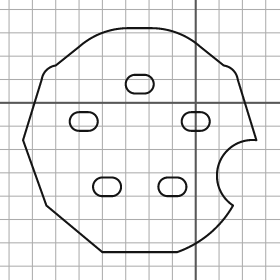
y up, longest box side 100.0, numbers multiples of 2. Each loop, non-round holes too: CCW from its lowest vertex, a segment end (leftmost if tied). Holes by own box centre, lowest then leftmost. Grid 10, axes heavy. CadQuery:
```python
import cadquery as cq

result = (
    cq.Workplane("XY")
    .moveTo(-40.0, -64.0)
    .lineTo(-8.0, -64.0)
    .threePointArc((6.0, -56.0), (16.0, -44.0))
    .threePointArc((10.0, -26.0), (26.0, -16.0))
    .lineTo(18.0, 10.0)
    .threePointArc((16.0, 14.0), (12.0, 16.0))
    .lineTo(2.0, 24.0)
    .threePointArc((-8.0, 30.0), (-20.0, 32.0))
    .lineTo(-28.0, 32.0)
    .threePointArc((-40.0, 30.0), (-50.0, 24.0))
    .lineTo(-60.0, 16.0)
    .threePointArc((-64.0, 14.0), (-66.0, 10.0))
    .lineTo(-74.0, -16.0)
    .lineTo(-64.0, -44.0)
    .close()
    .moveTo(-40.0, -40.0)
    .lineTo(-36.0, -40.0)
    .threePointArc((-32.0, -36.0), (-36.0, -32.0))
    .lineTo(-40.0, -32.0)
    .threePointArc((-44.0, -36.0), (-40.0, -40.0))
    .close()
    .moveTo(-12.0, -40.0)
    .lineTo(-8.0, -40.0)
    .threePointArc((-4.0, -36.0), (-8.0, -32.0))
    .lineTo(-12.0, -32.0)
    .threePointArc((-16.0, -36.0), (-12.0, -40.0))
    .close()
    .moveTo(-50.0, -12.0)
    .lineTo(-46.0, -12.0)
    .threePointArc((-42.0, -8.0), (-46.0, -4.0))
    .lineTo(-50.0, -4.0)
    .threePointArc((-54.0, -8.0), (-50.0, -12.0))
    .close()
    .moveTo(-2.0, -12.0)
    .lineTo(2.0, -12.0)
    .threePointArc((6.0, -8.0), (2.0, -4.0))
    .lineTo(-2.0, -4.0)
    .threePointArc((-6.0, -8.0), (-2.0, -12.0))
    .close()
    .moveTo(-26.0, 4.0)
    .lineTo(-22.0, 4.0)
    .threePointArc((-18.0, 8.0), (-22.0, 12.0))
    .lineTo(-26.0, 12.0)
    .threePointArc((-30.0, 8.0), (-26.0, 4.0))
    .close()
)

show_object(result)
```